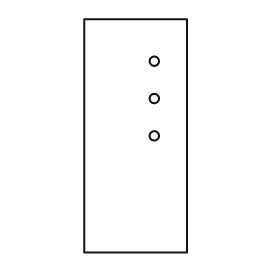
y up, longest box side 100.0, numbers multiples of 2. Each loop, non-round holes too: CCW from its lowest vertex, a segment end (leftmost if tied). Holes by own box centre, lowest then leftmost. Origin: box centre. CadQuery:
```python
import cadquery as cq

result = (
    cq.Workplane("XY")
    .moveTo(-22.0, -50.0)
    .lineTo(22.0, -50.0)
    .lineTo(22.0, 50.0)
    .lineTo(-22.0, 50.0)
    .close()
    .moveTo(8.0, 0.0)
    .circle(2.0)
    .moveTo(8.0, 16.0)
    .circle(2.0)
    .moveTo(8.0, 32.0)
    .circle(2.0)
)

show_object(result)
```